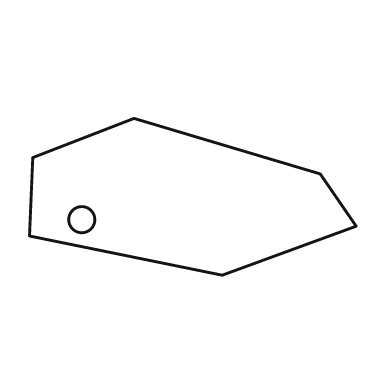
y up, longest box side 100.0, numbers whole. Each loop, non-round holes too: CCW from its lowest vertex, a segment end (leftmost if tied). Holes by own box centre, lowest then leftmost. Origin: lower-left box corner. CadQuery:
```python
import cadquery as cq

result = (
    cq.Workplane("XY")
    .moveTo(59.0, 0.0)
    .lineTo(100.0, 15.0)
    .lineTo(89.0, 31.0)
    .lineTo(32.0, 48.0)
    .lineTo(1.0, 36.0)
    .lineTo(0.0, 12.0)
    .close()
    .moveTo(16.0, 17.0)
    .circle(4.0)
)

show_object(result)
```